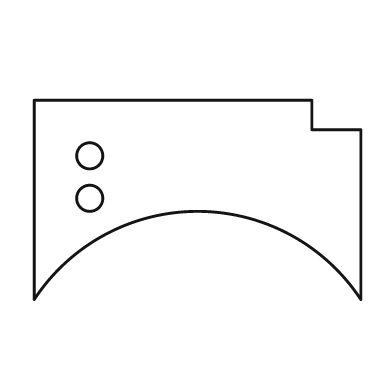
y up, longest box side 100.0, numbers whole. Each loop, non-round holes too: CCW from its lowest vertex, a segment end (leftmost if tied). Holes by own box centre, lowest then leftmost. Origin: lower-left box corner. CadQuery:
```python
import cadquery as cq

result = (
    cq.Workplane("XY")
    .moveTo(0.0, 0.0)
    .threePointArc((50.0, 27.0), (100.0, 0.0))
    .lineTo(100.0, 52.0)
    .lineTo(85.0, 52.0)
    .lineTo(85.0, 61.0)
    .lineTo(0.0, 61.0)
    .close()
    .moveTo(17.0, 31.0)
    .circle(4.0)
    .moveTo(17.0, 44.0)
    .circle(4.0)
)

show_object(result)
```